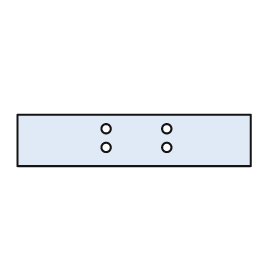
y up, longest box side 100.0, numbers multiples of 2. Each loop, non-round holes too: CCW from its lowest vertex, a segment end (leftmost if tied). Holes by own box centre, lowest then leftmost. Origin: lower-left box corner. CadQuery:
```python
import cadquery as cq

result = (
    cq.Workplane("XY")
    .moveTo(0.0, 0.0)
    .lineTo(100.0, 0.0)
    .lineTo(100.0, 22.0)
    .lineTo(0.0, 22.0)
    .close()
    .moveTo(38.0, 8.0)
    .circle(2.0)
    .moveTo(64.0, 8.0)
    .circle(2.0)
    .moveTo(38.0, 16.0)
    .circle(2.0)
    .moveTo(64.0, 16.0)
    .circle(2.0)
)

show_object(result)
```